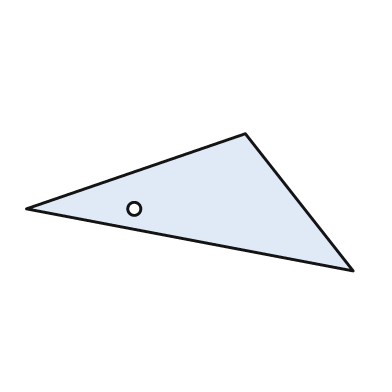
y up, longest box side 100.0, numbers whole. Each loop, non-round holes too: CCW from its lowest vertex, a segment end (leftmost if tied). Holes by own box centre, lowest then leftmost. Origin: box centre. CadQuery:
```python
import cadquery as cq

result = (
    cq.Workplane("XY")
    .moveTo(50.0, -21.0)
    .lineTo(17.0, 21.0)
    .lineTo(-50.0, -2.0)
    .close()
    .moveTo(-17.0, -2.0)
    .circle(2.0)
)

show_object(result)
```